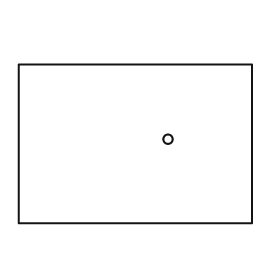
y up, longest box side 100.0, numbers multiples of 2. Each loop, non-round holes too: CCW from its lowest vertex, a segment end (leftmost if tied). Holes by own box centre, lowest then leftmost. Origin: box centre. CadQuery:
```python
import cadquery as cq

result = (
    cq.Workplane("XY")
    .moveTo(-50.0, -34.0)
    .lineTo(50.0, -34.0)
    .lineTo(50.0, 34.0)
    .lineTo(-50.0, 34.0)
    .close()
    .moveTo(14.0, 2.0)
    .circle(2.0)
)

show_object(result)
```